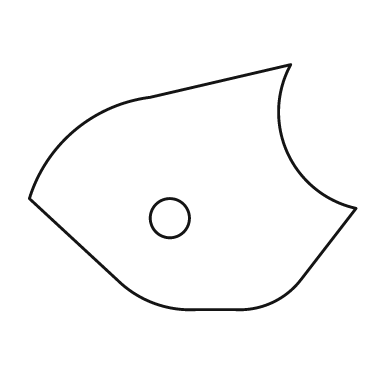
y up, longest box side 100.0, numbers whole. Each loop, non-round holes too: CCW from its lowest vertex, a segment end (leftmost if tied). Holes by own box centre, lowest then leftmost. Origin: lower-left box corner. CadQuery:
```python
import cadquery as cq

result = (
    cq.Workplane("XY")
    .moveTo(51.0, 0.0)
    .lineTo(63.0, 0.0)
    .threePointArc((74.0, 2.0), (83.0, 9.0))
    .lineTo(100.0, 31.0)
    .threePointArc((79.0, 48.0), (80.0, 75.0))
    .lineTo(37.0, 65.0)
    .threePointArc((14.0, 55.0), (0.0, 34.0))
    .lineTo(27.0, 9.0)
    .threePointArc((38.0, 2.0), (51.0, 0.0))
    .close()
    .moveTo(43.0, 28.0)
    .circle(6.0)
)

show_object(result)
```